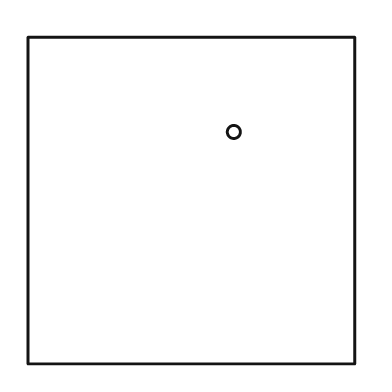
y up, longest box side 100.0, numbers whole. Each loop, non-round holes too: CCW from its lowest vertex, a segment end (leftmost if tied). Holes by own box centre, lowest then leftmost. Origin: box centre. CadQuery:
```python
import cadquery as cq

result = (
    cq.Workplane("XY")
    .moveTo(-50.0, -50.0)
    .lineTo(50.0, -50.0)
    .lineTo(50.0, 50.0)
    .lineTo(-50.0, 50.0)
    .close()
    .moveTo(13.0, 21.0)
    .circle(2.0)
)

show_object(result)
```